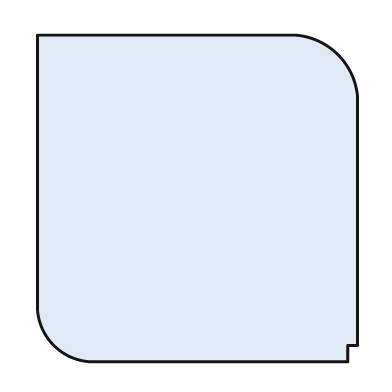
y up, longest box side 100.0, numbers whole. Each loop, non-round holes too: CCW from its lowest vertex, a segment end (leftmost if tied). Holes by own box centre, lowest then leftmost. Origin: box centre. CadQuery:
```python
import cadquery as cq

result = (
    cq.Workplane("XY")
    .moveTo(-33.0, -50.0)
    .lineTo(46.0, -50.0)
    .lineTo(46.0, -45.0)
    .lineTo(49.0, -45.0)
    .lineTo(49.0, 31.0)
    .threePointArc((43.0, 44.0), (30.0, 50.0))
    .lineTo(-49.0, 50.0)
    .lineTo(-49.0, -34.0)
    .threePointArc((-44.0, -45.0), (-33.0, -50.0))
    .close()
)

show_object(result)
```